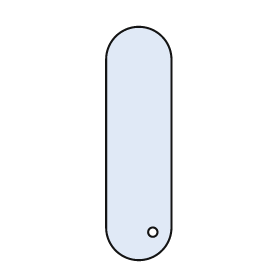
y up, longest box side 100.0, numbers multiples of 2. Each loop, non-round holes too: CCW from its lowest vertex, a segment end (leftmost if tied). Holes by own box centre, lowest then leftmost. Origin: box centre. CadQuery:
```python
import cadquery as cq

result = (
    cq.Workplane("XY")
    .moveTo(-14.0, -36.0)
    .threePointArc((0.0, -50.0), (14.0, -36.0))
    .lineTo(14.0, 36.0)
    .threePointArc((0.0, 50.0), (-14.0, 36.0))
    .close()
    .moveTo(6.0, -38.0)
    .circle(2.0)
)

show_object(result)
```